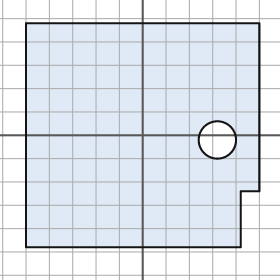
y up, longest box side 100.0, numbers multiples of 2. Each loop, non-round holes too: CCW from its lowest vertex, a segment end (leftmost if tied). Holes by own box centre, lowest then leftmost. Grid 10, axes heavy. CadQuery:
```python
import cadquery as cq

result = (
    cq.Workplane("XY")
    .moveTo(-50.0, -48.0)
    .lineTo(42.0, -48.0)
    .lineTo(42.0, -24.0)
    .lineTo(50.0, -24.0)
    .lineTo(50.0, 48.0)
    .lineTo(-50.0, 48.0)
    .close()
    .moveTo(32.0, -2.0)
    .circle(8.0)
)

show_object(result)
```